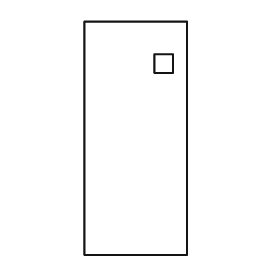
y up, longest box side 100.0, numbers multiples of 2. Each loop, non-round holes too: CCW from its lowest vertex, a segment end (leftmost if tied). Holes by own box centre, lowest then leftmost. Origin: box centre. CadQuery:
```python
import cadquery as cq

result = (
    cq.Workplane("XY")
    .moveTo(-22.0, -50.0)
    .lineTo(22.0, -50.0)
    .lineTo(22.0, 50.0)
    .lineTo(-22.0, 50.0)
    .close()
    .moveTo(8.0, 28.0)
    .lineTo(16.0, 28.0)
    .lineTo(16.0, 36.0)
    .lineTo(8.0, 36.0)
    .close()
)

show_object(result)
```